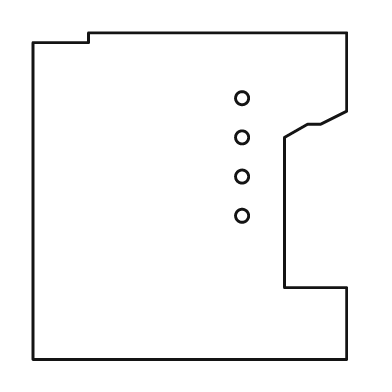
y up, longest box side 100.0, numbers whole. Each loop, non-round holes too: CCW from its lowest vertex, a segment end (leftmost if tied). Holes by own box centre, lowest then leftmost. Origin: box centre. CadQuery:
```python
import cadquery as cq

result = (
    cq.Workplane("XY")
    .moveTo(-48.0, -50.0)
    .lineTo(48.0, -50.0)
    .lineTo(48.0, -28.0)
    .lineTo(29.0, -28.0)
    .lineTo(29.0, 18.0)
    .lineTo(36.0, 22.0)
    .lineTo(40.0, 22.0)
    .lineTo(48.0, 26.0)
    .lineTo(48.0, 50.0)
    .lineTo(-31.0, 50.0)
    .lineTo(-31.0, 47.0)
    .lineTo(-48.0, 47.0)
    .close()
    .moveTo(16.0, -6.0)
    .circle(2.0)
    .moveTo(16.0, 6.0)
    .circle(2.0)
    .moveTo(16.0, 18.0)
    .circle(2.0)
    .moveTo(16.0, 30.0)
    .circle(2.0)
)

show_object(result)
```